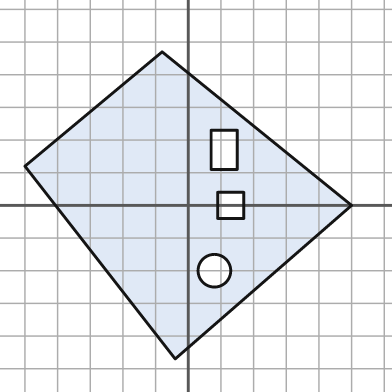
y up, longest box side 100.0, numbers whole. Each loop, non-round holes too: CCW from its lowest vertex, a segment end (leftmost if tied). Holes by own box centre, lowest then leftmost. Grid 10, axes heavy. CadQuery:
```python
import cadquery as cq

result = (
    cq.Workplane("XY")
    .moveTo(-4.0, -47.0)
    .lineTo(50.0, 0.0)
    .lineTo(-8.0, 47.0)
    .lineTo(-50.0, 12.0)
    .close()
    .moveTo(8.0, -20.0)
    .circle(5.0)
    .moveTo(9.0, -4.0)
    .lineTo(17.0, -4.0)
    .lineTo(17.0, 4.0)
    .lineTo(9.0, 4.0)
    .close()
    .moveTo(7.0, 11.0)
    .lineTo(15.0, 11.0)
    .lineTo(15.0, 23.0)
    .lineTo(7.0, 23.0)
    .close()
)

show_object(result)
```